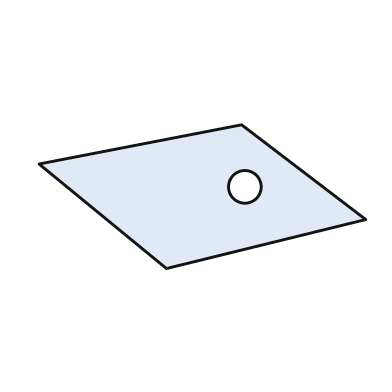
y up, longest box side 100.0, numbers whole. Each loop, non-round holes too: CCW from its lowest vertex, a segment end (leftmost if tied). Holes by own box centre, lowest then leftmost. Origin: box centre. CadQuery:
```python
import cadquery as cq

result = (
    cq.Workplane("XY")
    .moveTo(-11.0, -22.0)
    .lineTo(50.0, -7.0)
    .lineTo(12.0, 22.0)
    .lineTo(-50.0, 10.0)
    .close()
    .moveTo(13.0, 3.0)
    .circle(5.0)
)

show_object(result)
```